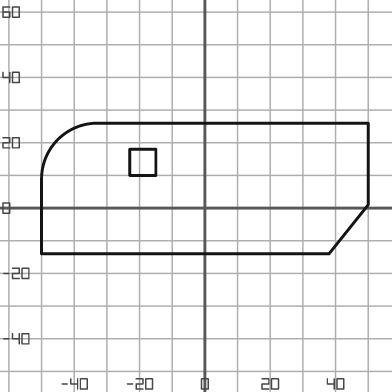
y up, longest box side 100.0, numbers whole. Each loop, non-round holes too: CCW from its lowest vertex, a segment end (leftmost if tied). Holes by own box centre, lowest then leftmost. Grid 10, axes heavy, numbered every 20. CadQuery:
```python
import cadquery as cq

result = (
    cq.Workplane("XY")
    .moveTo(-50.0, -14.0)
    .lineTo(38.0, -14.0)
    .lineTo(50.0, 1.0)
    .lineTo(50.0, 26.0)
    .lineTo(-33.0, 26.0)
    .threePointArc((-45.0, 21.0), (-50.0, 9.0))
    .close()
    .moveTo(-23.0, 10.0)
    .lineTo(-15.0, 10.0)
    .lineTo(-15.0, 18.0)
    .lineTo(-23.0, 18.0)
    .close()
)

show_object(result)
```